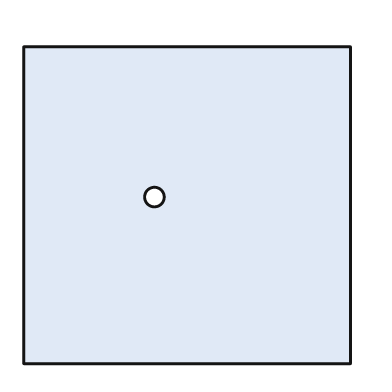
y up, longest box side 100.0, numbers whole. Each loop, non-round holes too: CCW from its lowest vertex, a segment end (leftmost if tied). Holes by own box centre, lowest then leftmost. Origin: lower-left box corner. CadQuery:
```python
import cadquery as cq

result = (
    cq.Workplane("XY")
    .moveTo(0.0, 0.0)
    .lineTo(100.0, 0.0)
    .lineTo(100.0, 97.0)
    .lineTo(0.0, 97.0)
    .close()
    .moveTo(40.0, 51.0)
    .circle(3.0)
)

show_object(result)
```